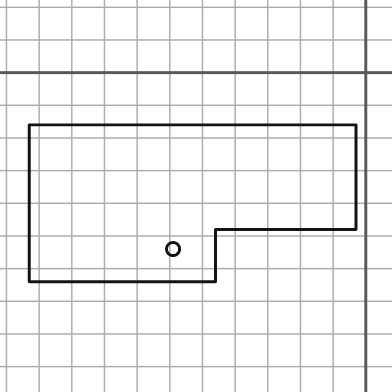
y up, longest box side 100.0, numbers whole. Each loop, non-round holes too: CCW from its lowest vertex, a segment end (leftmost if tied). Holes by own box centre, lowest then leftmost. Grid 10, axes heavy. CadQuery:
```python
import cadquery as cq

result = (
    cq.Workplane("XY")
    .moveTo(-103.0, -64.0)
    .lineTo(-46.0, -64.0)
    .lineTo(-46.0, -48.0)
    .lineTo(-3.0, -48.0)
    .lineTo(-3.0, -16.0)
    .lineTo(-103.0, -16.0)
    .close()
    .moveTo(-59.0, -54.0)
    .circle(2.0)
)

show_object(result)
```